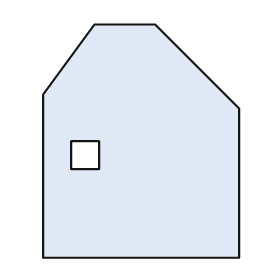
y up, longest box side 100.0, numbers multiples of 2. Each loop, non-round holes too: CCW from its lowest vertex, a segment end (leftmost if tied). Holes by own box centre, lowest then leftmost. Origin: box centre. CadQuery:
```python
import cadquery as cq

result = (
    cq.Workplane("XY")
    .moveTo(-42.0, -50.0)
    .lineTo(42.0, -50.0)
    .lineTo(42.0, 14.0)
    .lineTo(6.0, 50.0)
    .lineTo(-20.0, 50.0)
    .lineTo(-42.0, 20.0)
    .close()
    .moveTo(-30.0, -12.0)
    .lineTo(-18.0, -12.0)
    .lineTo(-18.0, 0.0)
    .lineTo(-30.0, 0.0)
    .close()
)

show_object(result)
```